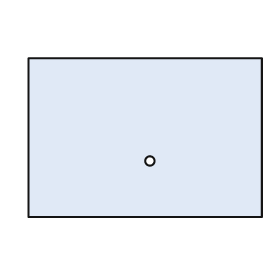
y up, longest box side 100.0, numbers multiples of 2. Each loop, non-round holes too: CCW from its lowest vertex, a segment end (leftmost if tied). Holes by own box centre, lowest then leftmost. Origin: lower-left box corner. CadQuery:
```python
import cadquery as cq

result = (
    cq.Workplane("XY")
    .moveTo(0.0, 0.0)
    .lineTo(100.0, 0.0)
    .lineTo(100.0, 68.0)
    .lineTo(0.0, 68.0)
    .close()
    .moveTo(52.0, 24.0)
    .circle(2.0)
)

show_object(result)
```